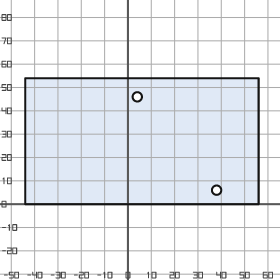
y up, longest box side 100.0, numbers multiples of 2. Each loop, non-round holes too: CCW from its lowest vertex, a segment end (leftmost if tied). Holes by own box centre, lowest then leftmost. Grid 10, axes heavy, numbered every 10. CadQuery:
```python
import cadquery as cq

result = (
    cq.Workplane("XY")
    .moveTo(-44.0, 0.0)
    .lineTo(56.0, 0.0)
    .lineTo(56.0, 54.0)
    .lineTo(-44.0, 54.0)
    .close()
    .moveTo(38.0, 6.0)
    .circle(2.0)
    .moveTo(4.0, 46.0)
    .circle(2.0)
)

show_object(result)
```